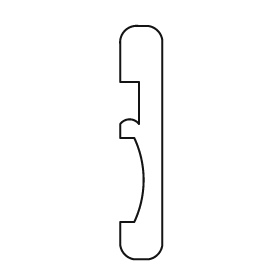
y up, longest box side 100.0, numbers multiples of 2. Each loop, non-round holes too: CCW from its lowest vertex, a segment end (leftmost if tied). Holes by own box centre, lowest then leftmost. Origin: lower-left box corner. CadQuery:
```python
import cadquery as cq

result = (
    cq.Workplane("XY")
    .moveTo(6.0, 0.0)
    .lineTo(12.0, 0.0)
    .threePointArc((16.0, 2.0), (18.0, 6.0))
    .lineTo(18.0, 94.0)
    .threePointArc((16.0, 98.0), (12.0, 100.0))
    .lineTo(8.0, 100.0)
    .threePointArc((2.0, 98.0), (0.0, 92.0))
    .lineTo(0.0, 76.0)
    .lineTo(8.0, 76.0)
    .lineTo(8.0, 58.0)
    .threePointArc((4.0, 60.0), (0.0, 58.0))
    .lineTo(0.0, 52.0)
    .lineTo(6.0, 52.0)
    .threePointArc((10.0, 34.0), (6.0, 16.0))
    .lineTo(0.0, 16.0)
    .lineTo(0.0, 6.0)
    .threePointArc((2.0, 2.0), (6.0, 0.0))
    .close()
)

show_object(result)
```